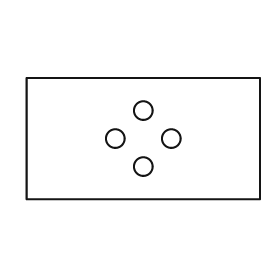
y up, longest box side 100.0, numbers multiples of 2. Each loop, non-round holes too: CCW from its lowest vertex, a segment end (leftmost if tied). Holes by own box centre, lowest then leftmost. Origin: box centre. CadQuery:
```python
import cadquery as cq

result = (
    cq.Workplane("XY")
    .moveTo(-50.0, -26.0)
    .lineTo(50.0, -26.0)
    .lineTo(50.0, 26.0)
    .lineTo(-50.0, 26.0)
    .close()
    .moveTo(0.0, -12.0)
    .circle(4.0)
    .moveTo(-12.0, 0.0)
    .circle(4.0)
    .moveTo(12.0, 0.0)
    .circle(4.0)
    .moveTo(0.0, 12.0)
    .circle(4.0)
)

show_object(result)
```